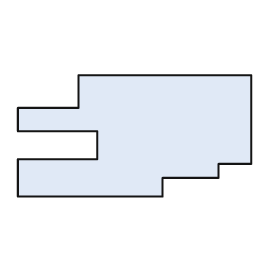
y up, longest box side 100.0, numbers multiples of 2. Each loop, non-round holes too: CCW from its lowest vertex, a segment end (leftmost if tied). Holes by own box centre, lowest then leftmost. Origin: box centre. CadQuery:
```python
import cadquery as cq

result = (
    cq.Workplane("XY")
    .moveTo(-50.0, -26.0)
    .lineTo(12.0, -26.0)
    .lineTo(12.0, -18.0)
    .lineTo(36.0, -18.0)
    .lineTo(36.0, -12.0)
    .lineTo(50.0, -12.0)
    .lineTo(50.0, 26.0)
    .lineTo(-24.0, 26.0)
    .lineTo(-24.0, 12.0)
    .lineTo(-50.0, 12.0)
    .lineTo(-50.0, 2.0)
    .lineTo(-16.0, 2.0)
    .lineTo(-16.0, -10.0)
    .lineTo(-50.0, -10.0)
    .close()
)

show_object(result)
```